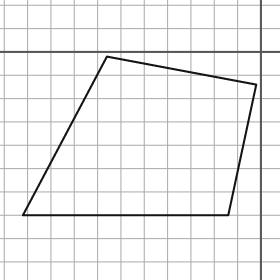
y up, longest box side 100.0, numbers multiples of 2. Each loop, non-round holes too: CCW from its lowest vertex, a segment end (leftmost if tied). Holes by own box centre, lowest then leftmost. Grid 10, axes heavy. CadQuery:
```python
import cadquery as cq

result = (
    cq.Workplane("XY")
    .moveTo(-102.0, -70.0)
    .lineTo(-14.0, -70.0)
    .lineTo(-2.0, -14.0)
    .lineTo(-66.0, -2.0)
    .close()
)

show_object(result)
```